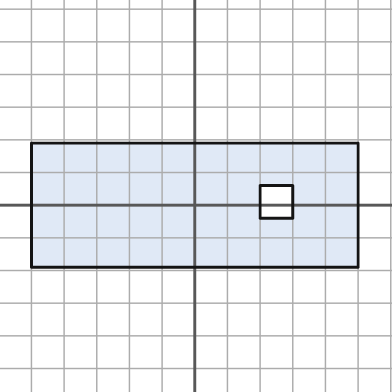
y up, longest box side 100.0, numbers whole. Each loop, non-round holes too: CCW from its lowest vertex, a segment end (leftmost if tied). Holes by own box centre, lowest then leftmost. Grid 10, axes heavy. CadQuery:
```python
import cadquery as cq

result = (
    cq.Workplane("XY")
    .moveTo(-50.0, -19.0)
    .lineTo(50.0, -19.0)
    .lineTo(50.0, 19.0)
    .lineTo(-50.0, 19.0)
    .close()
    .moveTo(20.0, -4.0)
    .lineTo(30.0, -4.0)
    .lineTo(30.0, 6.0)
    .lineTo(20.0, 6.0)
    .close()
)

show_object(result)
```